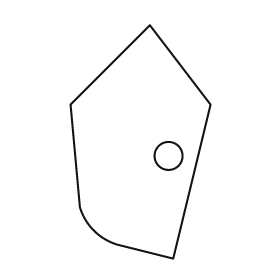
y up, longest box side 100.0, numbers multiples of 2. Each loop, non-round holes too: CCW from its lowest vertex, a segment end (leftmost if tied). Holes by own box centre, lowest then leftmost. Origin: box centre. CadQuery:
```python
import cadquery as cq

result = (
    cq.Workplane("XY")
    .moveTo(14.0, -50.0)
    .lineTo(30.0, 16.0)
    .lineTo(4.0, 50.0)
    .lineTo(-30.0, 16.0)
    .lineTo(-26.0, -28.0)
    .threePointArc((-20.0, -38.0), (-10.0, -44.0))
    .close()
    .moveTo(12.0, -6.0)
    .circle(6.0)
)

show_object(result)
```